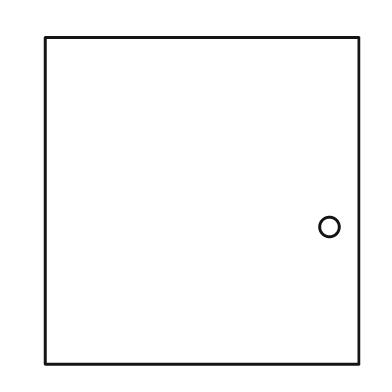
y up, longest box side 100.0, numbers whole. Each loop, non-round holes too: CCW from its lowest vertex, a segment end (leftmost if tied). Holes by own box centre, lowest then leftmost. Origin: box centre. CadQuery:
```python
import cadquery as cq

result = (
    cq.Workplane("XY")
    .moveTo(-48.0, -50.0)
    .lineTo(48.0, -50.0)
    .lineTo(48.0, 50.0)
    .lineTo(-48.0, 50.0)
    .close()
    .moveTo(39.0, -8.0)
    .circle(3.0)
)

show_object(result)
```